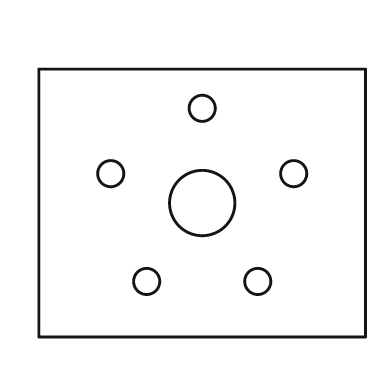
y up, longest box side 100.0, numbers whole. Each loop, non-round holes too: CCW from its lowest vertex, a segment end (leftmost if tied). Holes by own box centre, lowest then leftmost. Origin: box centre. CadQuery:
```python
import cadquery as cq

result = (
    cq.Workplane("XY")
    .moveTo(-50.0, -41.0)
    .lineTo(50.0, -41.0)
    .lineTo(50.0, 41.0)
    .lineTo(-50.0, 41.0)
    .close()
    .moveTo(-17.0, -24.0)
    .circle(4.0)
    .moveTo(17.0, -24.0)
    .circle(4.0)
    .moveTo(0.0, 0.0)
    .circle(10.0)
    .moveTo(-28.0, 9.0)
    .circle(4.0)
    .moveTo(28.0, 9.0)
    .circle(4.0)
    .moveTo(0.0, 29.0)
    .circle(4.0)
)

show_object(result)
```